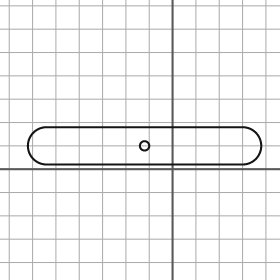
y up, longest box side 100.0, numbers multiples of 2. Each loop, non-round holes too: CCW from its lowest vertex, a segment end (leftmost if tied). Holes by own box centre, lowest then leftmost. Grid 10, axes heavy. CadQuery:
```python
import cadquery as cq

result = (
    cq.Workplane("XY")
    .moveTo(-54.0, 2.0)
    .lineTo(30.0, 2.0)
    .threePointArc((38.0, 10.0), (30.0, 18.0))
    .lineTo(-54.0, 18.0)
    .threePointArc((-62.0, 10.0), (-54.0, 2.0))
    .close()
    .moveTo(-12.0, 10.0)
    .circle(2.0)
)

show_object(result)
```